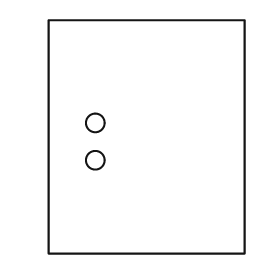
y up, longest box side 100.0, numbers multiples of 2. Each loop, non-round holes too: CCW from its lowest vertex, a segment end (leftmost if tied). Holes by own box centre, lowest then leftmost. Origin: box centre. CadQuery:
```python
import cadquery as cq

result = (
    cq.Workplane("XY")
    .moveTo(-42.0, -50.0)
    .lineTo(42.0, -50.0)
    .lineTo(42.0, 50.0)
    .lineTo(-42.0, 50.0)
    .close()
    .moveTo(-22.0, -10.0)
    .circle(4.0)
    .moveTo(-22.0, 6.0)
    .circle(4.0)
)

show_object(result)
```